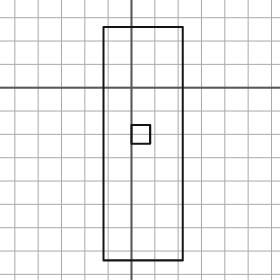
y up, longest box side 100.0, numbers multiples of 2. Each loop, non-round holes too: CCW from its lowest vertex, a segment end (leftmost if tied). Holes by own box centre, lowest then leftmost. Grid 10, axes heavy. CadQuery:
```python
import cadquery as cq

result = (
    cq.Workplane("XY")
    .moveTo(-12.0, -74.0)
    .lineTo(22.0, -74.0)
    .lineTo(22.0, 26.0)
    .lineTo(-12.0, 26.0)
    .close()
    .moveTo(0.0, -24.0)
    .lineTo(8.0, -24.0)
    .lineTo(8.0, -16.0)
    .lineTo(0.0, -16.0)
    .close()
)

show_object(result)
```